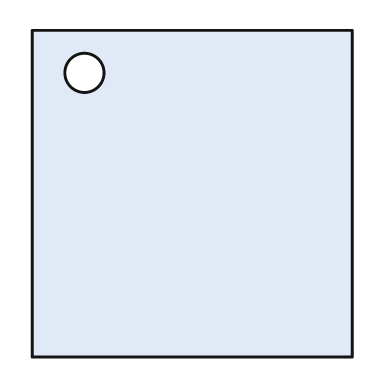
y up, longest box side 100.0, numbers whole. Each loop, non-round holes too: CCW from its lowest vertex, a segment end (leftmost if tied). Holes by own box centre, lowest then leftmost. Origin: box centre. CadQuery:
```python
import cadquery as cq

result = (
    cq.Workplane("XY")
    .moveTo(-49.0, -50.0)
    .lineTo(49.0, -50.0)
    .lineTo(49.0, 50.0)
    .lineTo(-49.0, 50.0)
    .close()
    .moveTo(-33.0, 37.0)
    .circle(6.0)
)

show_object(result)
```